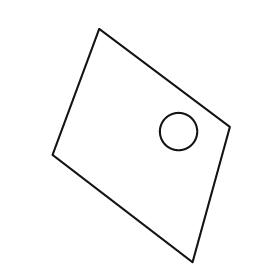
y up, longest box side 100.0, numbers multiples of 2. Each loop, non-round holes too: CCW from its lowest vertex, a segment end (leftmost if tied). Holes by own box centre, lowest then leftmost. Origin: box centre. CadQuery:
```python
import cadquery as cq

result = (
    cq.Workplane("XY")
    .moveTo(22.0, -50.0)
    .lineTo(38.0, 8.0)
    .lineTo(-18.0, 50.0)
    .lineTo(-38.0, -4.0)
    .close()
    .moveTo(16.0, 6.0)
    .circle(8.0)
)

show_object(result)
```